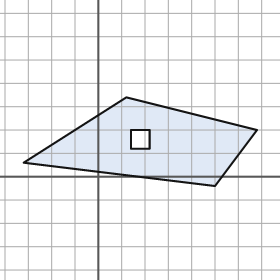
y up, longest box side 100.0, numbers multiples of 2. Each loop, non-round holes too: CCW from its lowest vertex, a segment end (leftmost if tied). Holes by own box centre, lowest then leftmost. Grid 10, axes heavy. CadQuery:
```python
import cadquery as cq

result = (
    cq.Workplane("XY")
    .moveTo(50.0, -4.0)
    .lineTo(68.0, 20.0)
    .lineTo(12.0, 34.0)
    .lineTo(-32.0, 6.0)
    .close()
    .moveTo(14.0, 12.0)
    .lineTo(22.0, 12.0)
    .lineTo(22.0, 20.0)
    .lineTo(14.0, 20.0)
    .close()
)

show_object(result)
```